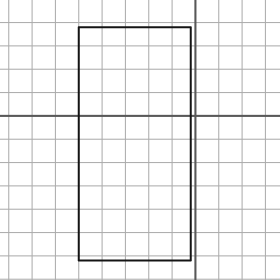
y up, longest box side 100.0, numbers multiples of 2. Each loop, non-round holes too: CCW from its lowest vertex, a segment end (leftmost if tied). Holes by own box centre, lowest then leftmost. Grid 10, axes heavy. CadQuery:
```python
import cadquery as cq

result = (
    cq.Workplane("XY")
    .moveTo(-50.0, -62.0)
    .lineTo(-2.0, -62.0)
    .lineTo(-2.0, 38.0)
    .lineTo(-50.0, 38.0)
    .close()
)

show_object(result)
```